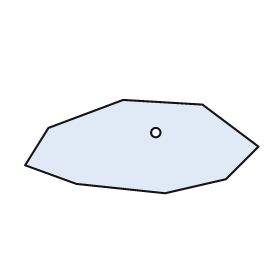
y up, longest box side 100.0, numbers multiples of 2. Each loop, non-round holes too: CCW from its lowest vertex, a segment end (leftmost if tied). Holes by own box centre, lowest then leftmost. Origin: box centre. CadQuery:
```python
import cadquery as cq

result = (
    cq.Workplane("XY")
    .moveTo(10.0, -20.0)
    .lineTo(36.0, -14.0)
    .lineTo(50.0, 0.0)
    .lineTo(26.0, 18.0)
    .lineTo(-8.0, 20.0)
    .lineTo(-40.0, 8.0)
    .lineTo(-50.0, -8.0)
    .lineTo(-28.0, -16.0)
    .close()
    .moveTo(6.0, 6.0)
    .circle(2.0)
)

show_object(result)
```